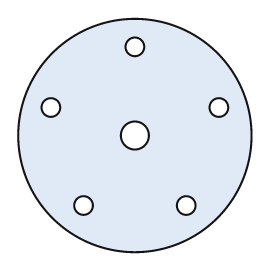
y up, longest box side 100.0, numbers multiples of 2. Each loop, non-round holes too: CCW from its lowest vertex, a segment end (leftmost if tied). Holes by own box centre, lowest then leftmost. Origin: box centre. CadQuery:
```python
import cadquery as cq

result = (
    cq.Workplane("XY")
    .moveTo(0.0, 0.0)
    .circle(50.0)
    .moveTo(-22.0, -30.0)
    .circle(4.0)
    .moveTo(22.0, -30.0)
    .circle(4.0)
    .moveTo(0.0, 0.0)
    .circle(6.0)
    .moveTo(-36.0, 12.0)
    .circle(4.0)
    .moveTo(36.0, 12.0)
    .circle(4.0)
    .moveTo(0.0, 38.0)
    .circle(4.0)
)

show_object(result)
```